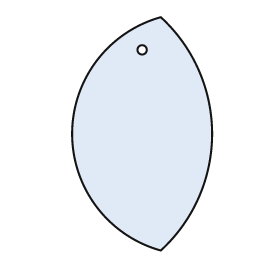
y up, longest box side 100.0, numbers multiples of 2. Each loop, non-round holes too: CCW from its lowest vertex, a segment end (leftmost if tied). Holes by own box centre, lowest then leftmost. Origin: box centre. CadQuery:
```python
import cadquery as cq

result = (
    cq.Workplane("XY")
    .moveTo(8.0, -50.0)
    .threePointArc((30.0, 0.0), (8.0, 50.0))
    .threePointArc((-30.0, 0.0), (8.0, -50.0))
    .close()
    .moveTo(0.0, 36.0)
    .circle(2.0)
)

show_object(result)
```